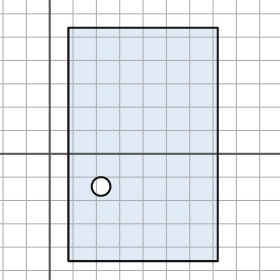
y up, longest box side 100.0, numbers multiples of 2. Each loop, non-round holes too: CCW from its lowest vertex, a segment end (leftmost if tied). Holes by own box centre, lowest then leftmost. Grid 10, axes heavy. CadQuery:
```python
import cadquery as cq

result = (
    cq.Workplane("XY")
    .moveTo(8.0, -46.0)
    .lineTo(72.0, -46.0)
    .lineTo(72.0, 54.0)
    .lineTo(8.0, 54.0)
    .close()
    .moveTo(22.0, -14.0)
    .circle(4.0)
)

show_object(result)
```